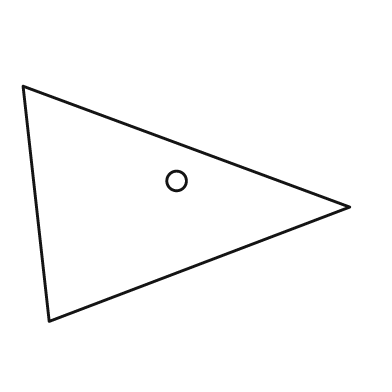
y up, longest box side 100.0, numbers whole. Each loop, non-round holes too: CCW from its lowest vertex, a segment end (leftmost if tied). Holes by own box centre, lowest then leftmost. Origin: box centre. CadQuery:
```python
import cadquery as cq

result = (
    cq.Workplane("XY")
    .moveTo(-42.0, -36.0)
    .lineTo(50.0, -1.0)
    .lineTo(-50.0, 36.0)
    .close()
    .moveTo(-3.0, 7.0)
    .circle(3.0)
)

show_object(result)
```